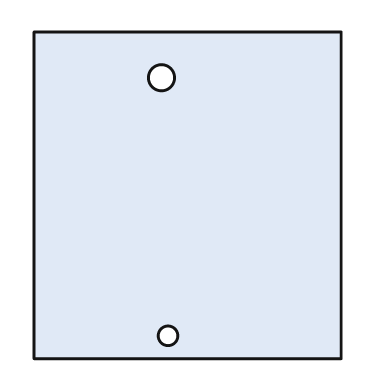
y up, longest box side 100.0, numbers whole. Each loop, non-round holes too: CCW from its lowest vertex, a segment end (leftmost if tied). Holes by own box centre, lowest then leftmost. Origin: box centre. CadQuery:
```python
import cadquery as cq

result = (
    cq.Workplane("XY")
    .moveTo(-47.0, -50.0)
    .lineTo(47.0, -50.0)
    .lineTo(47.0, 50.0)
    .lineTo(-47.0, 50.0)
    .close()
    .moveTo(-6.0, -43.0)
    .circle(3.0)
    .moveTo(-8.0, 36.0)
    .circle(4.0)
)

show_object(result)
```